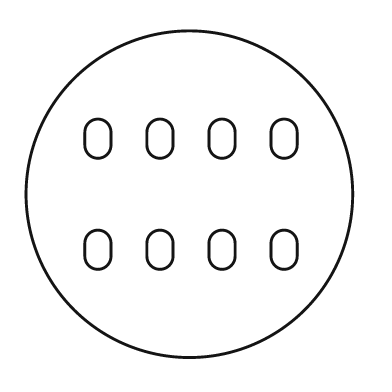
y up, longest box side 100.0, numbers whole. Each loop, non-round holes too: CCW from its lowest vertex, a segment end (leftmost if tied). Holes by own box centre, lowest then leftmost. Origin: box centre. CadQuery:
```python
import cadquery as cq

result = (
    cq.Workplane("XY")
    .moveTo(0.0, 0.0)
    .circle(50.0)
    .moveTo(-32.0, -19.0)
    .threePointArc((-28.0, -23.0), (-24.0, -19.0))
    .lineTo(-24.0, -15.0)
    .threePointArc((-28.0, -11.0), (-32.0, -15.0))
    .close()
    .moveTo(-13.0, -19.0)
    .threePointArc((-9.0, -23.0), (-5.0, -19.0))
    .lineTo(-5.0, -15.0)
    .threePointArc((-9.0, -11.0), (-13.0, -15.0))
    .close()
    .moveTo(6.0, -19.0)
    .threePointArc((10.0, -23.0), (14.0, -19.0))
    .lineTo(14.0, -15.0)
    .threePointArc((10.0, -11.0), (6.0, -15.0))
    .close()
    .moveTo(25.0, -19.0)
    .threePointArc((29.0, -23.0), (33.0, -19.0))
    .lineTo(33.0, -15.0)
    .threePointArc((29.0, -11.0), (25.0, -15.0))
    .close()
    .moveTo(-32.0, 15.0)
    .threePointArc((-28.0, 11.0), (-24.0, 15.0))
    .lineTo(-24.0, 19.0)
    .threePointArc((-28.0, 23.0), (-32.0, 19.0))
    .close()
    .moveTo(-13.0, 15.0)
    .threePointArc((-9.0, 11.0), (-5.0, 15.0))
    .lineTo(-5.0, 19.0)
    .threePointArc((-9.0, 23.0), (-13.0, 19.0))
    .close()
    .moveTo(6.0, 15.0)
    .threePointArc((10.0, 11.0), (14.0, 15.0))
    .lineTo(14.0, 19.0)
    .threePointArc((10.0, 23.0), (6.0, 19.0))
    .close()
    .moveTo(25.0, 15.0)
    .threePointArc((29.0, 11.0), (33.0, 15.0))
    .lineTo(33.0, 19.0)
    .threePointArc((29.0, 23.0), (25.0, 19.0))
    .close()
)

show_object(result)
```